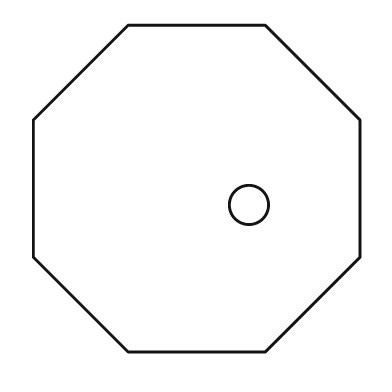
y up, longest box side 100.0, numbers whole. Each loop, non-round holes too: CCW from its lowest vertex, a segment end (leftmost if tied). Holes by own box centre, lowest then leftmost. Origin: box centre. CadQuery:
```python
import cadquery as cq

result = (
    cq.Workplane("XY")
    .moveTo(-21.0, -50.0)
    .lineTo(21.0, -50.0)
    .lineTo(50.0, -21.0)
    .lineTo(50.0, 21.0)
    .lineTo(21.0, 50.0)
    .lineTo(-21.0, 50.0)
    .lineTo(-50.0, 21.0)
    .lineTo(-50.0, -21.0)
    .close()
    .moveTo(16.0, -5.0)
    .circle(6.0)
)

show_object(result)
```